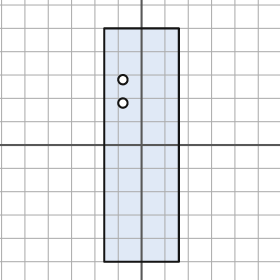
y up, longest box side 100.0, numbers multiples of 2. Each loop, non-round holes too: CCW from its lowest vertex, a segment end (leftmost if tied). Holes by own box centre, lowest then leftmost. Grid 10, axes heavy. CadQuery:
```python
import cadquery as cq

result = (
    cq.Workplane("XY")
    .moveTo(-16.0, -50.0)
    .lineTo(16.0, -50.0)
    .lineTo(16.0, 50.0)
    .lineTo(-16.0, 50.0)
    .close()
    .moveTo(-8.0, 18.0)
    .circle(2.0)
    .moveTo(-8.0, 28.0)
    .circle(2.0)
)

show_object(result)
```